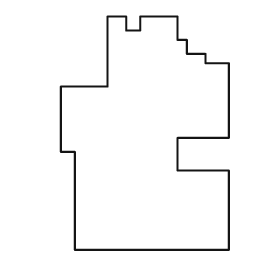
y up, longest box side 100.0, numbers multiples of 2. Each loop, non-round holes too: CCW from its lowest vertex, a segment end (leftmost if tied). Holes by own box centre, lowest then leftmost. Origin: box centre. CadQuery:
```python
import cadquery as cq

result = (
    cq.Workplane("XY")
    .moveTo(-30.0, -50.0)
    .lineTo(36.0, -50.0)
    .lineTo(36.0, -16.0)
    .lineTo(14.0, -16.0)
    .lineTo(14.0, -2.0)
    .lineTo(36.0, -2.0)
    .lineTo(36.0, 30.0)
    .lineTo(26.0, 30.0)
    .lineTo(26.0, 34.0)
    .lineTo(18.0, 34.0)
    .lineTo(18.0, 40.0)
    .lineTo(14.0, 40.0)
    .lineTo(14.0, 50.0)
    .lineTo(-2.0, 50.0)
    .lineTo(-2.0, 44.0)
    .lineTo(-8.0, 44.0)
    .lineTo(-8.0, 50.0)
    .lineTo(-16.0, 50.0)
    .lineTo(-16.0, 20.0)
    .lineTo(-36.0, 20.0)
    .lineTo(-36.0, -8.0)
    .lineTo(-30.0, -8.0)
    .close()
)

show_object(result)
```